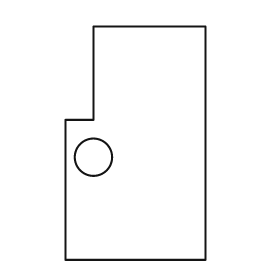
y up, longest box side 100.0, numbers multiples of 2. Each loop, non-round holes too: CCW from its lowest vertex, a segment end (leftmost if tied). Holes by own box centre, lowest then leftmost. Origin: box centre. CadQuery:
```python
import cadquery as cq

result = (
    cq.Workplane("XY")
    .moveTo(-30.0, -50.0)
    .lineTo(30.0, -50.0)
    .lineTo(30.0, 50.0)
    .lineTo(-18.0, 50.0)
    .lineTo(-18.0, 10.0)
    .lineTo(-30.0, 10.0)
    .close()
    .moveTo(-18.0, -6.0)
    .circle(8.0)
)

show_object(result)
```